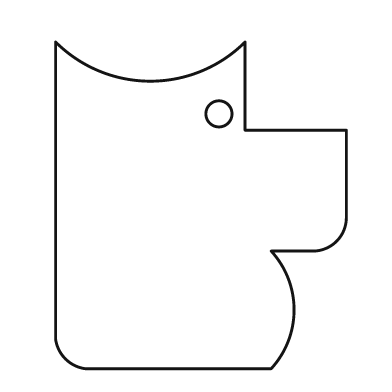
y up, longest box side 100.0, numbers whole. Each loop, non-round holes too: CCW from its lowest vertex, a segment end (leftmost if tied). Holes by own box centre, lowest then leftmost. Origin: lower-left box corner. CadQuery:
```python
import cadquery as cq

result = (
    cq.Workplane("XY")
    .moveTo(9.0, 0.0)
    .lineTo(66.0, 0.0)
    .threePointArc((73.0, 18.0), (66.0, 36.0))
    .lineTo(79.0, 36.0)
    .threePointArc((86.0, 39.0), (89.0, 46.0))
    .lineTo(89.0, 73.0)
    .lineTo(58.0, 73.0)
    .lineTo(58.0, 100.0)
    .threePointArc((29.0, 88.0), (0.0, 100.0))
    .lineTo(0.0, 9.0)
    .threePointArc((3.0, 3.0), (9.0, 0.0))
    .close()
    .moveTo(50.0, 78.0)
    .circle(4.0)
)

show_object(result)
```